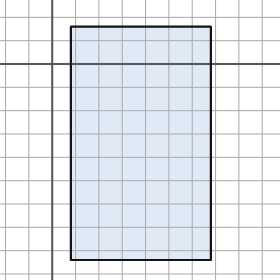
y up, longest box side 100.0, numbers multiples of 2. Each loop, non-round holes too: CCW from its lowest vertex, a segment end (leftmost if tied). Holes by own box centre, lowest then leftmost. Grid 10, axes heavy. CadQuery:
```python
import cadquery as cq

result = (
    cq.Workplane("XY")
    .moveTo(8.0, -84.0)
    .lineTo(68.0, -84.0)
    .lineTo(68.0, 16.0)
    .lineTo(8.0, 16.0)
    .close()
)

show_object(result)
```